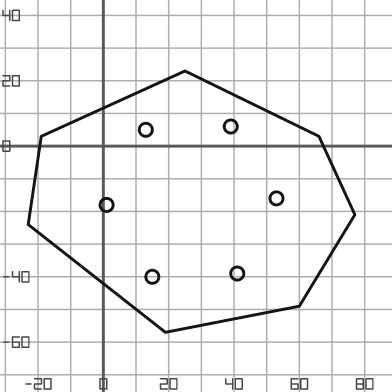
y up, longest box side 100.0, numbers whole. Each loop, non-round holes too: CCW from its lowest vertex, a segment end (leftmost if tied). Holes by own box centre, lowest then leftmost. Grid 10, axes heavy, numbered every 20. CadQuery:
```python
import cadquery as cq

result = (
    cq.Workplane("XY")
    .moveTo(19.0, -57.0)
    .lineTo(60.0, -49.0)
    .lineTo(77.0, -21.0)
    .lineTo(66.0, 3.0)
    .lineTo(25.0, 23.0)
    .lineTo(-19.0, 3.0)
    .lineTo(-23.0, -24.0)
    .close()
    .moveTo(15.0, -40.0)
    .circle(2.0)
    .moveTo(41.0, -39.0)
    .circle(2.0)
    .moveTo(1.0, -18.0)
    .circle(2.0)
    .moveTo(53.0, -16.0)
    .circle(2.0)
    .moveTo(13.0, 5.0)
    .circle(2.0)
    .moveTo(39.0, 6.0)
    .circle(2.0)
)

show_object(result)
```